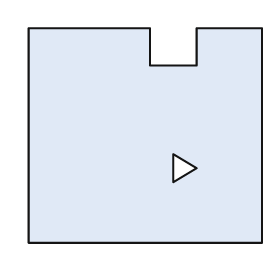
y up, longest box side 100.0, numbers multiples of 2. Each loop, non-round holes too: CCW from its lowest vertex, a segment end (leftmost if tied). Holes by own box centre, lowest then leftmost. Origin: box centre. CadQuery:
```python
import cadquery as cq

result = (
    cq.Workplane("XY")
    .moveTo(-50.0, -46.0)
    .lineTo(50.0, -46.0)
    .lineTo(50.0, 46.0)
    .lineTo(22.0, 46.0)
    .lineTo(22.0, 30.0)
    .lineTo(2.0, 30.0)
    .lineTo(2.0, 46.0)
    .lineTo(-50.0, 46.0)
    .close()
    .moveTo(12.0, -20.0)
    .lineTo(22.0, -14.0)
    .lineTo(12.0, -8.0)
    .close()
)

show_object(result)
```